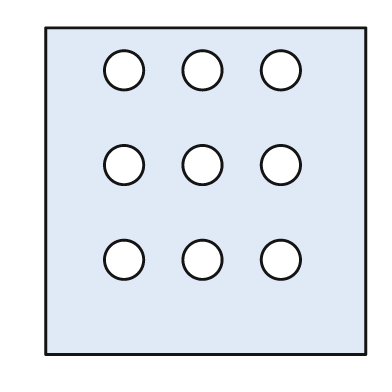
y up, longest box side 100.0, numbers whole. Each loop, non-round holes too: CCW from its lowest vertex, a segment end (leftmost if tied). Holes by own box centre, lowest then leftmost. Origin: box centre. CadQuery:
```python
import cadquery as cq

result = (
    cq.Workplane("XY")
    .moveTo(-49.0, -50.0)
    .lineTo(49.0, -50.0)
    .lineTo(49.0, 50.0)
    .lineTo(-49.0, 50.0)
    .close()
    .moveTo(-25.0, -21.0)
    .circle(6.0)
    .moveTo(-1.0, -21.0)
    .circle(6.0)
    .moveTo(23.0, -21.0)
    .circle(6.0)
    .moveTo(-25.0, 8.0)
    .circle(6.0)
    .moveTo(-1.0, 8.0)
    .circle(6.0)
    .moveTo(23.0, 8.0)
    .circle(6.0)
    .moveTo(-25.0, 37.0)
    .circle(6.0)
    .moveTo(-1.0, 37.0)
    .circle(6.0)
    .moveTo(23.0, 37.0)
    .circle(6.0)
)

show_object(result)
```